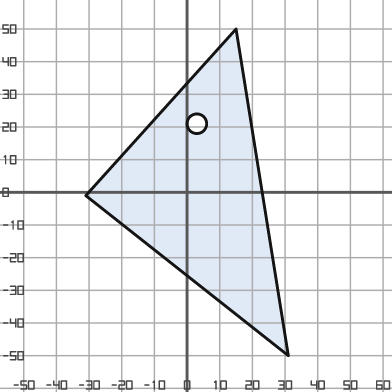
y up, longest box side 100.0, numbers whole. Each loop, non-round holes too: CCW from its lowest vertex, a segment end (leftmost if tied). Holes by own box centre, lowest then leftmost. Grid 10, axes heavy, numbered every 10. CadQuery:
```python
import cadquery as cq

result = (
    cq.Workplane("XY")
    .moveTo(31.0, -50.0)
    .lineTo(15.0, 50.0)
    .lineTo(-31.0, -1.0)
    .close()
    .moveTo(3.0, 21.0)
    .circle(3.0)
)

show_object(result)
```